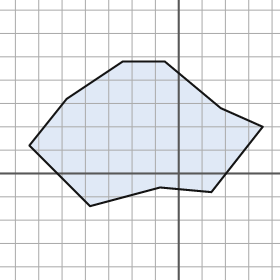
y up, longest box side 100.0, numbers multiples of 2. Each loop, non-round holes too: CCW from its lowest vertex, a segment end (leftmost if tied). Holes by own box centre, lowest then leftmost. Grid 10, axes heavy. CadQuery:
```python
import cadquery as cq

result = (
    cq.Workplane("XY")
    .moveTo(-38.0, -14.0)
    .lineTo(-8.0, -6.0)
    .lineTo(14.0, -8.0)
    .lineTo(36.0, 20.0)
    .lineTo(18.0, 28.0)
    .lineTo(-6.0, 48.0)
    .lineTo(-24.0, 48.0)
    .lineTo(-48.0, 32.0)
    .lineTo(-64.0, 12.0)
    .close()
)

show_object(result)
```